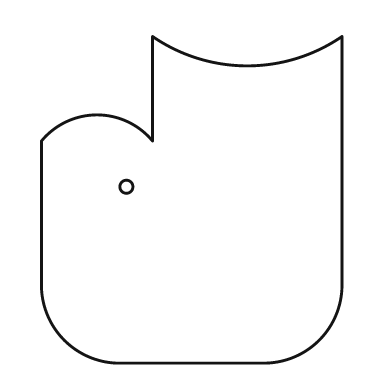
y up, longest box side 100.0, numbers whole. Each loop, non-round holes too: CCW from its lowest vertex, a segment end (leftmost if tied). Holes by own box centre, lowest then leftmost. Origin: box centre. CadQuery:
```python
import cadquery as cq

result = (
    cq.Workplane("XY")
    .moveTo(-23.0, -50.0)
    .lineTo(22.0, -50.0)
    .threePointArc((39.0, -43.0), (46.0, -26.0))
    .lineTo(46.0, 50.0)
    .threePointArc((17.0, 41.0), (-12.0, 50.0))
    .lineTo(-12.0, 18.0)
    .threePointArc((-29.0, 26.0), (-46.0, 18.0))
    .lineTo(-46.0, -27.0)
    .threePointArc((-39.0, -43.0), (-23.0, -50.0))
    .close()
    .moveTo(-20.0, 4.0)
    .circle(2.0)
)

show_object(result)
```